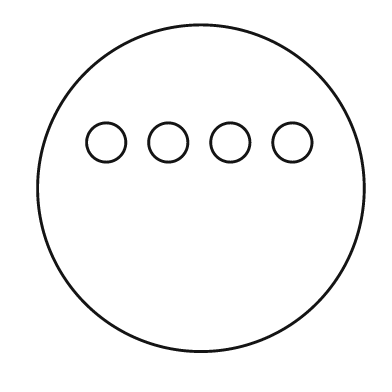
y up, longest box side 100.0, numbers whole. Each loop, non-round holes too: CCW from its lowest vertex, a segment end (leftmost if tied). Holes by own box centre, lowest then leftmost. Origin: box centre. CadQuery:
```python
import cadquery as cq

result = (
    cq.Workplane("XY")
    .moveTo(0.0, 0.0)
    .circle(50.0)
    .moveTo(-29.0, 14.0)
    .circle(6.0)
    .moveTo(-10.0, 14.0)
    .circle(6.0)
    .moveTo(9.0, 14.0)
    .circle(6.0)
    .moveTo(28.0, 14.0)
    .circle(6.0)
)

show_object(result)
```